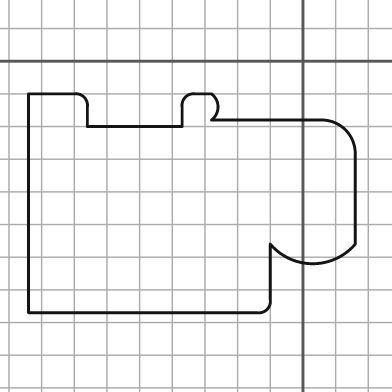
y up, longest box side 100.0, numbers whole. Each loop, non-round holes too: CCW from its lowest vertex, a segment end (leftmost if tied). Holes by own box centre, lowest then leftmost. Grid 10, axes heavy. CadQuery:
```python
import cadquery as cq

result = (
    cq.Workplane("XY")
    .moveTo(-84.0, -77.0)
    .lineTo(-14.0, -77.0)
    .threePointArc((-11.0, -76.0), (-10.0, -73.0))
    .lineTo(-10.0, -56.0)
    .threePointArc((3.0, -62.0), (16.0, -56.0))
    .lineTo(16.0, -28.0)
    .threePointArc((13.0, -21.0), (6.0, -18.0))
    .lineTo(-28.0, -18.0)
    .threePointArc((-26.0, -14.0), (-28.0, -10.0))
    .lineTo(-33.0, -10.0)
    .threePointArc((-36.0, -11.0), (-37.0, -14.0))
    .lineTo(-37.0, -20.0)
    .lineTo(-66.0, -20.0)
    .lineTo(-66.0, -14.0)
    .threePointArc((-67.0, -11.0), (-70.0, -10.0))
    .lineTo(-84.0, -10.0)
    .close()
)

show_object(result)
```